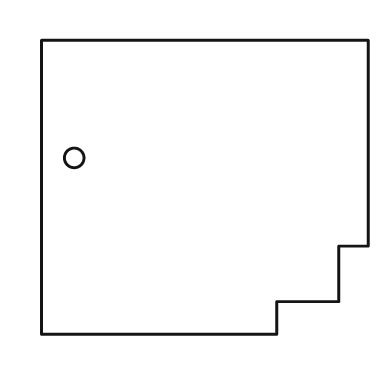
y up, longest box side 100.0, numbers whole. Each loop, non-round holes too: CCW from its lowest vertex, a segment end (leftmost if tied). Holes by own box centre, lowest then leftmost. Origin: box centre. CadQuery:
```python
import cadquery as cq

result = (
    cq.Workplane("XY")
    .moveTo(-50.0, -45.0)
    .lineTo(22.0, -45.0)
    .lineTo(22.0, -35.0)
    .lineTo(41.0, -35.0)
    .lineTo(41.0, -18.0)
    .lineTo(50.0, -18.0)
    .lineTo(50.0, 45.0)
    .lineTo(-50.0, 45.0)
    .close()
    .moveTo(-40.0, 9.0)
    .circle(3.0)
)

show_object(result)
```